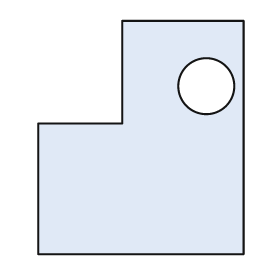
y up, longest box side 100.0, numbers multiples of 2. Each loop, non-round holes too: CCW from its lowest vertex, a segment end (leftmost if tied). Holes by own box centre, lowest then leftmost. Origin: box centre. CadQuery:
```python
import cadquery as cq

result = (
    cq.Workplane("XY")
    .moveTo(-44.0, -50.0)
    .lineTo(44.0, -50.0)
    .lineTo(44.0, 50.0)
    .lineTo(-8.0, 50.0)
    .lineTo(-8.0, 6.0)
    .lineTo(-44.0, 6.0)
    .close()
    .moveTo(28.0, 22.0)
    .circle(12.0)
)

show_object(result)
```